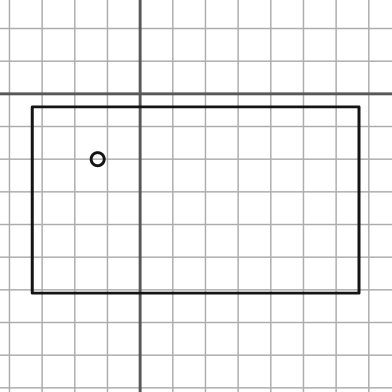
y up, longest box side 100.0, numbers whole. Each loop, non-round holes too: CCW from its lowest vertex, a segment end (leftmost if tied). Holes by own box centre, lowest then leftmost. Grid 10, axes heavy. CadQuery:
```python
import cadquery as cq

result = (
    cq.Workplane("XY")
    .moveTo(-33.0, -61.0)
    .lineTo(67.0, -61.0)
    .lineTo(67.0, -4.0)
    .lineTo(-33.0, -4.0)
    .close()
    .moveTo(-13.0, -20.0)
    .circle(2.0)
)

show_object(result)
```